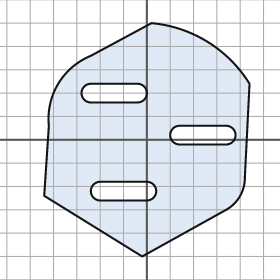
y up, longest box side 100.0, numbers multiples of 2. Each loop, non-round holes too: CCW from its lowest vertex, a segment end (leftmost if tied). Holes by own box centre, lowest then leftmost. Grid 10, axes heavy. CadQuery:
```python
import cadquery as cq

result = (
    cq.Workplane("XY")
    .moveTo(-2.0, -50.0)
    .lineTo(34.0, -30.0)
    .threePointArc((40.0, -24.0), (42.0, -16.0))
    .lineTo(44.0, 24.0)
    .threePointArc((26.0, 42.0), (2.0, 50.0))
    .lineTo(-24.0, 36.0)
    .threePointArc((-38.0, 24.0), (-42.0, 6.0))
    .lineTo(-44.0, -24.0)
    .close()
    .moveTo(-20.0, -26.0)
    .lineTo(0.0, -26.0)
    .threePointArc((4.0, -22.0), (0.0, -18.0))
    .lineTo(-20.0, -18.0)
    .threePointArc((-24.0, -22.0), (-20.0, -26.0))
    .close()
    .moveTo(14.0, -2.0)
    .lineTo(34.0, -2.0)
    .threePointArc((38.0, 2.0), (34.0, 6.0))
    .lineTo(14.0, 6.0)
    .threePointArc((10.0, 2.0), (14.0, -2.0))
    .close()
    .moveTo(-24.0, 16.0)
    .lineTo(-4.0, 16.0)
    .threePointArc((0.0, 20.0), (-4.0, 24.0))
    .lineTo(-24.0, 24.0)
    .threePointArc((-28.0, 20.0), (-24.0, 16.0))
    .close()
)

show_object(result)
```